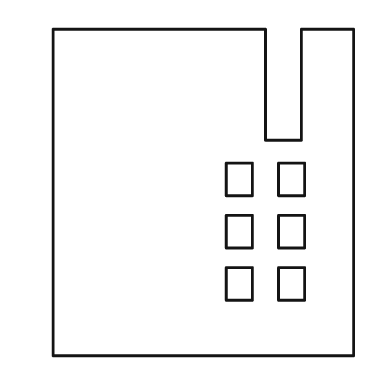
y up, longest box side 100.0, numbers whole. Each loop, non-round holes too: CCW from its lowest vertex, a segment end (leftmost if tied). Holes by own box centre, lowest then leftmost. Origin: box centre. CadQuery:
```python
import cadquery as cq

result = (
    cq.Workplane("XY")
    .moveTo(-46.0, -50.0)
    .lineTo(46.0, -50.0)
    .lineTo(46.0, 50.0)
    .lineTo(30.0, 50.0)
    .lineTo(30.0, 16.0)
    .lineTo(19.0, 16.0)
    .lineTo(19.0, 50.0)
    .lineTo(-46.0, 50.0)
    .close()
    .moveTo(7.0, -33.0)
    .lineTo(15.0, -33.0)
    .lineTo(15.0, -23.0)
    .lineTo(7.0, -23.0)
    .close()
    .moveTo(23.0, -33.0)
    .lineTo(31.0, -33.0)
    .lineTo(31.0, -23.0)
    .lineTo(23.0, -23.0)
    .close()
    .moveTo(7.0, -17.0)
    .lineTo(15.0, -17.0)
    .lineTo(15.0, -7.0)
    .lineTo(7.0, -7.0)
    .close()
    .moveTo(23.0, -17.0)
    .lineTo(31.0, -17.0)
    .lineTo(31.0, -7.0)
    .lineTo(23.0, -7.0)
    .close()
    .moveTo(7.0, -1.0)
    .lineTo(15.0, -1.0)
    .lineTo(15.0, 9.0)
    .lineTo(7.0, 9.0)
    .close()
    .moveTo(23.0, -1.0)
    .lineTo(31.0, -1.0)
    .lineTo(31.0, 9.0)
    .lineTo(23.0, 9.0)
    .close()
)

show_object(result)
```